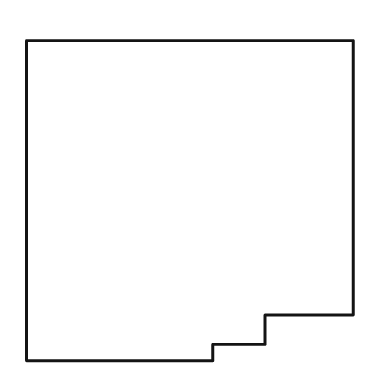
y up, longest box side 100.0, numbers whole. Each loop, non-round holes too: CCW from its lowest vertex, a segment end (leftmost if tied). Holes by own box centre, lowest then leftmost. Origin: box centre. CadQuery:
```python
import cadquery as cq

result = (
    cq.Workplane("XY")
    .moveTo(-50.0, -49.0)
    .lineTo(7.0, -49.0)
    .lineTo(7.0, -44.0)
    .lineTo(23.0, -44.0)
    .lineTo(23.0, -35.0)
    .lineTo(50.0, -35.0)
    .lineTo(50.0, 49.0)
    .lineTo(-50.0, 49.0)
    .close()
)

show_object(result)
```